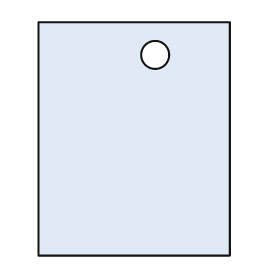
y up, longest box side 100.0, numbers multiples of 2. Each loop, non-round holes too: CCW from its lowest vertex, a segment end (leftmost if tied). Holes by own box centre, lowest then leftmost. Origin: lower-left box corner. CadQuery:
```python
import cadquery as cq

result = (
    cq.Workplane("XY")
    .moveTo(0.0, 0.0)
    .lineTo(82.0, 0.0)
    .lineTo(82.0, 100.0)
    .lineTo(0.0, 100.0)
    .close()
    .moveTo(50.0, 86.0)
    .circle(6.0)
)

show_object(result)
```